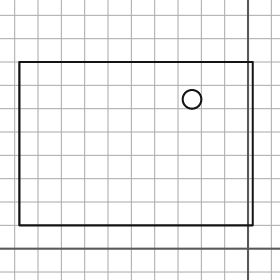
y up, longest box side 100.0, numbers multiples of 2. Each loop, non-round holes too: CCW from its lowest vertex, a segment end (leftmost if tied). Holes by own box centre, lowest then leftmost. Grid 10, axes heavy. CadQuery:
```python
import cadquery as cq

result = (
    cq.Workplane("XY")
    .moveTo(-98.0, 10.0)
    .lineTo(2.0, 10.0)
    .lineTo(2.0, 80.0)
    .lineTo(-98.0, 80.0)
    .close()
    .moveTo(-24.0, 64.0)
    .circle(4.0)
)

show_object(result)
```